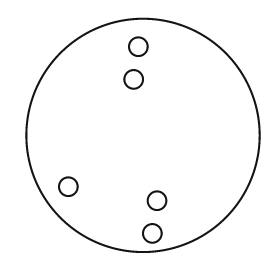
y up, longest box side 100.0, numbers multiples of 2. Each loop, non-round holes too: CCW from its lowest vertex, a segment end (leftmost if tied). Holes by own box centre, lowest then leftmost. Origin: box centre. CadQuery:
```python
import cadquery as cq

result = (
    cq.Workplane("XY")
    .moveTo(0.0, 0.0)
    .circle(50.0)
    .moveTo(4.0, -42.0)
    .circle(4.0)
    .moveTo(6.0, -28.0)
    .circle(4.0)
    .moveTo(-32.0, -22.0)
    .circle(4.0)
    .moveTo(-4.0, 24.0)
    .circle(4.0)
    .moveTo(-2.0, 38.0)
    .circle(4.0)
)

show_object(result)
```